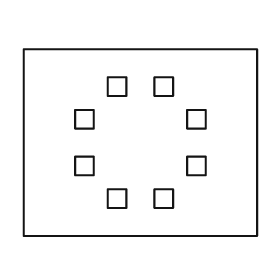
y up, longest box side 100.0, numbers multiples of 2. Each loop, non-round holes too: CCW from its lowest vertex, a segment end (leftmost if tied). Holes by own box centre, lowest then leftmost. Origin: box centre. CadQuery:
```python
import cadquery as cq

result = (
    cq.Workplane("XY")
    .moveTo(-50.0, -40.0)
    .lineTo(50.0, -40.0)
    .lineTo(50.0, 40.0)
    .lineTo(-50.0, 40.0)
    .close()
    .moveTo(-14.0, -28.0)
    .lineTo(-6.0, -28.0)
    .lineTo(-6.0, -20.0)
    .lineTo(-14.0, -20.0)
    .close()
    .moveTo(6.0, -28.0)
    .lineTo(14.0, -28.0)
    .lineTo(14.0, -20.0)
    .lineTo(6.0, -20.0)
    .close()
    .moveTo(-28.0, -14.0)
    .lineTo(-20.0, -14.0)
    .lineTo(-20.0, -6.0)
    .lineTo(-28.0, -6.0)
    .close()
    .moveTo(20.0, -14.0)
    .lineTo(28.0, -14.0)
    .lineTo(28.0, -6.0)
    .lineTo(20.0, -6.0)
    .close()
    .moveTo(-28.0, 6.0)
    .lineTo(-20.0, 6.0)
    .lineTo(-20.0, 14.0)
    .lineTo(-28.0, 14.0)
    .close()
    .moveTo(20.0, 6.0)
    .lineTo(28.0, 6.0)
    .lineTo(28.0, 14.0)
    .lineTo(20.0, 14.0)
    .close()
    .moveTo(-14.0, 20.0)
    .lineTo(-6.0, 20.0)
    .lineTo(-6.0, 28.0)
    .lineTo(-14.0, 28.0)
    .close()
    .moveTo(6.0, 20.0)
    .lineTo(14.0, 20.0)
    .lineTo(14.0, 28.0)
    .lineTo(6.0, 28.0)
    .close()
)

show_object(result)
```